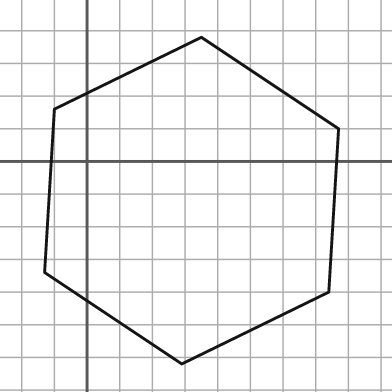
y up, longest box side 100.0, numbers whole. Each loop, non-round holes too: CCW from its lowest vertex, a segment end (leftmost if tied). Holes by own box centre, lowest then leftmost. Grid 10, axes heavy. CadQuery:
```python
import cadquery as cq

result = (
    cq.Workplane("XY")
    .moveTo(29.0, -62.0)
    .lineTo(74.0, -40.0)
    .lineTo(77.0, 10.0)
    .lineTo(35.0, 38.0)
    .lineTo(-10.0, 16.0)
    .lineTo(-13.0, -34.0)
    .close()
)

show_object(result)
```